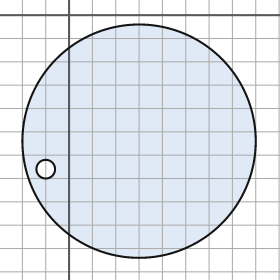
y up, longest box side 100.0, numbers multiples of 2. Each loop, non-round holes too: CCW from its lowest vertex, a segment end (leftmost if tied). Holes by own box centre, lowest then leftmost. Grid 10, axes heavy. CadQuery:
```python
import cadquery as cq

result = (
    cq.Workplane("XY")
    .moveTo(30.0, -54.0)
    .circle(50.0)
    .moveTo(-10.0, -66.0)
    .circle(4.0)
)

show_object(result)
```